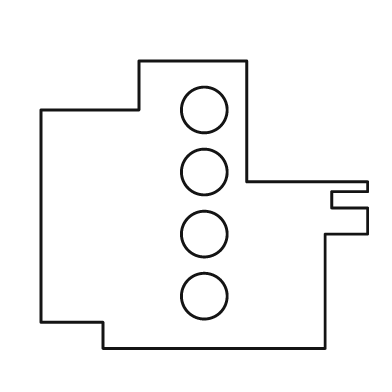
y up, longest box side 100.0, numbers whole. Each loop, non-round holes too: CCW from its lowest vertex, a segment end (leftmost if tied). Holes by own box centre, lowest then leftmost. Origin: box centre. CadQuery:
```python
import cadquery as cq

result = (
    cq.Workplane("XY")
    .moveTo(-31.0, -44.0)
    .lineTo(37.0, -44.0)
    .lineTo(37.0, -9.0)
    .lineTo(50.0, -9.0)
    .lineTo(50.0, -1.0)
    .lineTo(39.0, -1.0)
    .lineTo(39.0, 4.0)
    .lineTo(50.0, 4.0)
    .lineTo(50.0, 7.0)
    .lineTo(13.0, 7.0)
    .lineTo(13.0, 44.0)
    .lineTo(-20.0, 44.0)
    .lineTo(-20.0, 29.0)
    .lineTo(-50.0, 29.0)
    .lineTo(-50.0, -36.0)
    .lineTo(-31.0, -36.0)
    .close()
    .moveTo(0.0, -28.0)
    .circle(7.0)
    .moveTo(0.0, -9.0)
    .circle(7.0)
    .moveTo(0.0, 10.0)
    .circle(7.0)
    .moveTo(0.0, 29.0)
    .circle(7.0)
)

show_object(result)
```